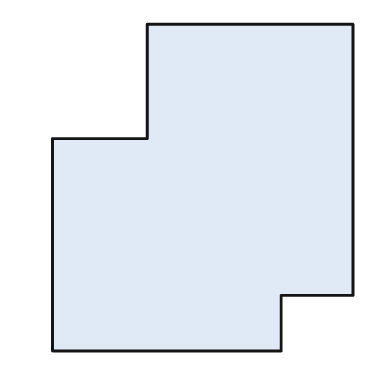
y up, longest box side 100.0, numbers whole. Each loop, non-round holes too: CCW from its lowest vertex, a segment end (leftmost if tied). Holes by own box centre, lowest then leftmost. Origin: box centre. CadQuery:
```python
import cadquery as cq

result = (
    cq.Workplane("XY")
    .moveTo(-46.0, -50.0)
    .lineTo(24.0, -50.0)
    .lineTo(24.0, -33.0)
    .lineTo(46.0, -33.0)
    .lineTo(46.0, 50.0)
    .lineTo(-17.0, 50.0)
    .lineTo(-17.0, 15.0)
    .lineTo(-46.0, 15.0)
    .close()
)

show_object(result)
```